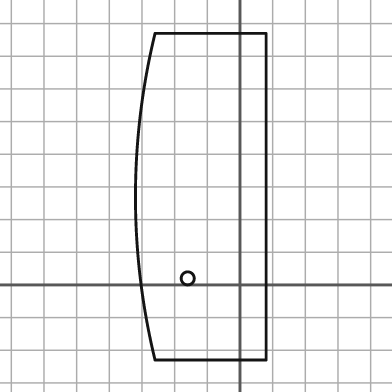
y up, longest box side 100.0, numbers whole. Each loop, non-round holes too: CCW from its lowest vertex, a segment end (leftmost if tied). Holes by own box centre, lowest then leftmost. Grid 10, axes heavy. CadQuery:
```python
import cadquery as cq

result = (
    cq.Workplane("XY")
    .moveTo(-26.0, -23.0)
    .lineTo(8.0, -23.0)
    .lineTo(8.0, 77.0)
    .lineTo(-26.0, 77.0)
    .threePointArc((-32.0, 27.0), (-26.0, -23.0))
    .close()
    .moveTo(-16.0, 2.0)
    .circle(2.0)
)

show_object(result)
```